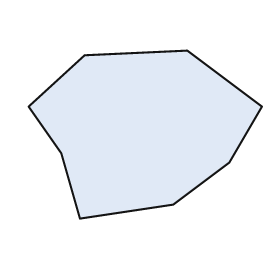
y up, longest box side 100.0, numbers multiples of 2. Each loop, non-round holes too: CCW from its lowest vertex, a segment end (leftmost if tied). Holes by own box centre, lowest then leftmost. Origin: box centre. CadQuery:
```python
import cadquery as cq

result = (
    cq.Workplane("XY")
    .moveTo(-28.0, -36.0)
    .lineTo(12.0, -30.0)
    .lineTo(36.0, -12.0)
    .lineTo(50.0, 12.0)
    .lineTo(18.0, 36.0)
    .lineTo(-26.0, 34.0)
    .lineTo(-50.0, 12.0)
    .lineTo(-36.0, -8.0)
    .close()
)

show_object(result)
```